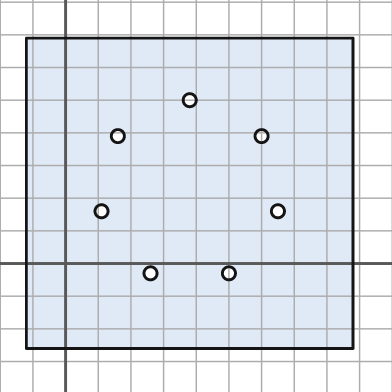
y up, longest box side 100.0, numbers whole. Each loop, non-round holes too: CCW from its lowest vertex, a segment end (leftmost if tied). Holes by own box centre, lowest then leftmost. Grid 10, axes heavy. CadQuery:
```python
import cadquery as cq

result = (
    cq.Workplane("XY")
    .moveTo(-12.0, -26.0)
    .lineTo(88.0, -26.0)
    .lineTo(88.0, 69.0)
    .lineTo(-12.0, 69.0)
    .close()
    .moveTo(26.0, -3.0)
    .circle(2.0)
    .moveTo(50.0, -3.0)
    .circle(2.0)
    .moveTo(11.0, 16.0)
    .circle(2.0)
    .moveTo(65.0, 16.0)
    .circle(2.0)
    .moveTo(16.0, 39.0)
    .circle(2.0)
    .moveTo(60.0, 39.0)
    .circle(2.0)
    .moveTo(38.0, 50.0)
    .circle(2.0)
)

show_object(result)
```